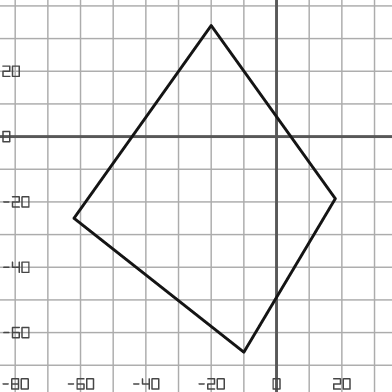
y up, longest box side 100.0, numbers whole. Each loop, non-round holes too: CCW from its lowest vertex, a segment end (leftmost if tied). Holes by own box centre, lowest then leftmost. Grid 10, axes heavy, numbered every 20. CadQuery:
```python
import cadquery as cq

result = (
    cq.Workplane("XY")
    .moveTo(-10.0, -66.0)
    .lineTo(18.0, -19.0)
    .lineTo(-20.0, 34.0)
    .lineTo(-62.0, -25.0)
    .close()
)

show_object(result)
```